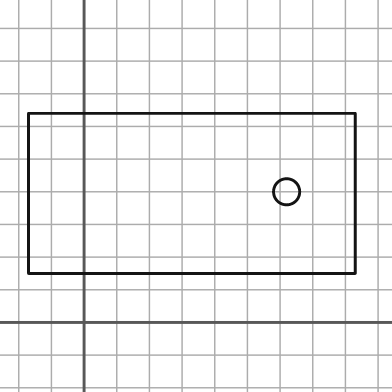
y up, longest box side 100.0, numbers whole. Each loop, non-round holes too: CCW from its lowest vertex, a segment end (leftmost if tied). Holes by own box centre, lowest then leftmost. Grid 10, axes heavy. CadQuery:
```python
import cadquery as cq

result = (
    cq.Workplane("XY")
    .moveTo(-17.0, 15.0)
    .lineTo(83.0, 15.0)
    .lineTo(83.0, 64.0)
    .lineTo(-17.0, 64.0)
    .close()
    .moveTo(62.0, 40.0)
    .circle(4.0)
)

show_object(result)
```